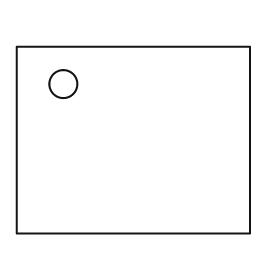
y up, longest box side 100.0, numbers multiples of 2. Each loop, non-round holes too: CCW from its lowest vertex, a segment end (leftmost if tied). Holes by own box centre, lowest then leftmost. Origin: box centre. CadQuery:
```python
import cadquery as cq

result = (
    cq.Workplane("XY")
    .moveTo(-50.0, -40.0)
    .lineTo(50.0, -40.0)
    .lineTo(50.0, 40.0)
    .lineTo(-50.0, 40.0)
    .close()
    .moveTo(-30.0, 24.0)
    .circle(6.0)
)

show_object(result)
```